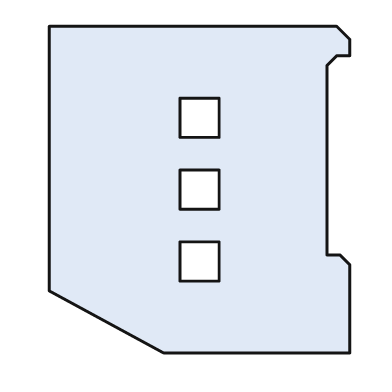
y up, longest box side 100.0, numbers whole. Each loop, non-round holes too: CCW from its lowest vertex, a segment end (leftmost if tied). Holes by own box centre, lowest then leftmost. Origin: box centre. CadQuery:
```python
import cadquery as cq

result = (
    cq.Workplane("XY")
    .moveTo(-11.0, -50.0)
    .lineTo(46.0, -50.0)
    .lineTo(46.0, -23.0)
    .lineTo(43.0, -20.0)
    .lineTo(39.0, -20.0)
    .lineTo(39.0, 38.0)
    .lineTo(42.0, 41.0)
    .lineTo(46.0, 41.0)
    .lineTo(46.0, 46.0)
    .lineTo(42.0, 50.0)
    .lineTo(-46.0, 50.0)
    .lineTo(-46.0, -31.0)
    .close()
    .moveTo(-6.0, -28.0)
    .lineTo(6.0, -28.0)
    .lineTo(6.0, -16.0)
    .lineTo(-6.0, -16.0)
    .close()
    .moveTo(-6.0, -6.0)
    .lineTo(6.0, -6.0)
    .lineTo(6.0, 6.0)
    .lineTo(-6.0, 6.0)
    .close()
    .moveTo(-6.0, 16.0)
    .lineTo(6.0, 16.0)
    .lineTo(6.0, 28.0)
    .lineTo(-6.0, 28.0)
    .close()
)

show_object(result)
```